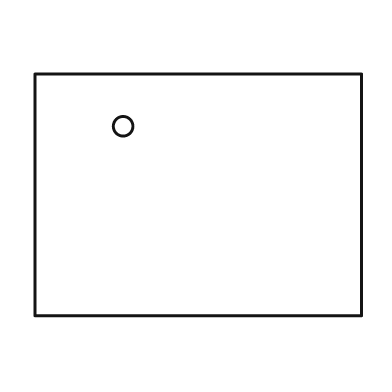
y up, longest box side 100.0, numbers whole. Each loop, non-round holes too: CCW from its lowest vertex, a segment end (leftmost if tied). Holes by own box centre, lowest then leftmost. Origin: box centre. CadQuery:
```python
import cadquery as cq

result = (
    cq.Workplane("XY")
    .moveTo(-50.0, -37.0)
    .lineTo(50.0, -37.0)
    .lineTo(50.0, 37.0)
    .lineTo(-50.0, 37.0)
    .close()
    .moveTo(-23.0, 21.0)
    .circle(3.0)
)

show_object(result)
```